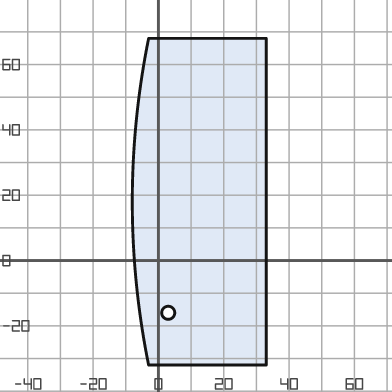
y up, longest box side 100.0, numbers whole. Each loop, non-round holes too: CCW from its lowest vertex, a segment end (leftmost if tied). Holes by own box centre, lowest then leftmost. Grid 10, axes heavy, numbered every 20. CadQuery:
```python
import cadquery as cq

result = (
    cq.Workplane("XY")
    .moveTo(-3.0, -32.0)
    .lineTo(33.0, -32.0)
    .lineTo(33.0, 68.0)
    .lineTo(-3.0, 68.0)
    .threePointArc((-8.0, 18.0), (-3.0, -32.0))
    .close()
    .moveTo(3.0, -16.0)
    .circle(2.0)
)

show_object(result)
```